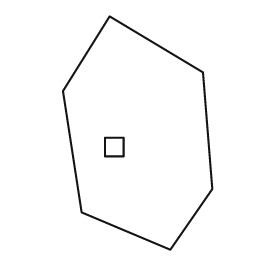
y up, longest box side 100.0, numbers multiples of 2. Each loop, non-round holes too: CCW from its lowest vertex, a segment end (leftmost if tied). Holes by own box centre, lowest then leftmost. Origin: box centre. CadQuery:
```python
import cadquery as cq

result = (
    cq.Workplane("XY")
    .moveTo(14.0, -50.0)
    .lineTo(32.0, -24.0)
    .lineTo(28.0, 26.0)
    .lineTo(-12.0, 50.0)
    .lineTo(-32.0, 18.0)
    .lineTo(-24.0, -34.0)
    .close()
    .moveTo(-14.0, -10.0)
    .lineTo(-6.0, -10.0)
    .lineTo(-6.0, -2.0)
    .lineTo(-14.0, -2.0)
    .close()
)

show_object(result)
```